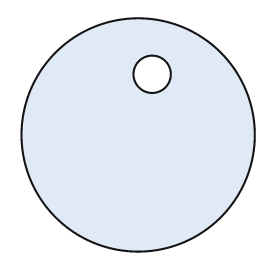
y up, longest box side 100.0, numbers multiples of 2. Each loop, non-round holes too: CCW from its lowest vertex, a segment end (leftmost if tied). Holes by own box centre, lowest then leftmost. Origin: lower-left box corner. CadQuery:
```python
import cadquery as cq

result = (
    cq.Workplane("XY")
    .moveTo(50.0, 50.0)
    .circle(50.0)
    .moveTo(56.0, 76.0)
    .circle(8.0)
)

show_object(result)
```